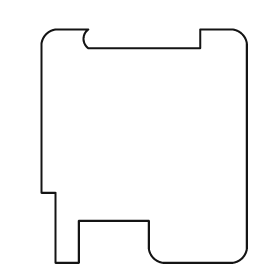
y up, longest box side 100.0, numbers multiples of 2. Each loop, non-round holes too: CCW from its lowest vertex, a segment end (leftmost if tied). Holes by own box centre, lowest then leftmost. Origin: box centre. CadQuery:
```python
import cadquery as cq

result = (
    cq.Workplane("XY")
    .moveTo(-38.0, -50.0)
    .lineTo(-28.0, -50.0)
    .lineTo(-28.0, -32.0)
    .lineTo(2.0, -32.0)
    .lineTo(2.0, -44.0)
    .threePointArc((4.0, -48.0), (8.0, -50.0))
    .lineTo(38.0, -50.0)
    .threePointArc((42.0, -48.0), (44.0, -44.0))
    .lineTo(44.0, 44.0)
    .threePointArc((42.0, 48.0), (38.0, 50.0))
    .lineTo(24.0, 50.0)
    .lineTo(24.0, 42.0)
    .lineTo(-24.0, 42.0)
    .threePointArc((-26.0, 46.0), (-24.0, 50.0))
    .lineTo(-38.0, 50.0)
    .threePointArc((-42.0, 48.0), (-44.0, 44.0))
    .lineTo(-44.0, -20.0)
    .lineTo(-38.0, -20.0)
    .close()
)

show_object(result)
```